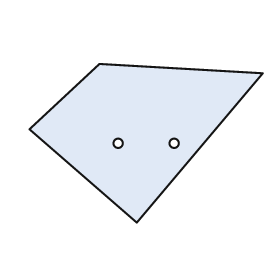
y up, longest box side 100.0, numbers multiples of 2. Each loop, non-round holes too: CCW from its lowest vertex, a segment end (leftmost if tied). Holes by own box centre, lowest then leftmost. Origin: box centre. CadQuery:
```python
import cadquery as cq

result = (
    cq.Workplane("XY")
    .moveTo(-4.0, -34.0)
    .lineTo(50.0, 30.0)
    .lineTo(-20.0, 34.0)
    .lineTo(-50.0, 6.0)
    .close()
    .moveTo(-12.0, 0.0)
    .circle(2.0)
    .moveTo(12.0, 0.0)
    .circle(2.0)
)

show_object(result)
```